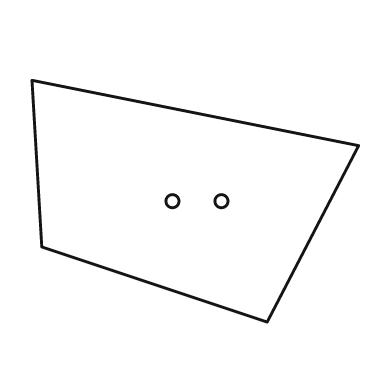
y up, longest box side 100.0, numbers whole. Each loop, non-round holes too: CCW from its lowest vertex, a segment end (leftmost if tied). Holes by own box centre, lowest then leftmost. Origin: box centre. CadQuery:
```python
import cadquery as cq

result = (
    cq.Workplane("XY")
    .moveTo(22.0, -37.0)
    .lineTo(50.0, 17.0)
    .lineTo(-50.0, 37.0)
    .lineTo(-47.0, -14.0)
    .close()
    .moveTo(-7.0, 0.0)
    .circle(2.0)
    .moveTo(8.0, 0.0)
    .circle(2.0)
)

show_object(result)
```